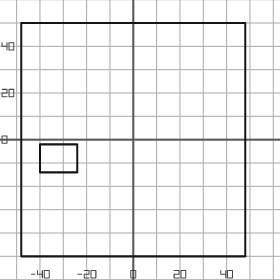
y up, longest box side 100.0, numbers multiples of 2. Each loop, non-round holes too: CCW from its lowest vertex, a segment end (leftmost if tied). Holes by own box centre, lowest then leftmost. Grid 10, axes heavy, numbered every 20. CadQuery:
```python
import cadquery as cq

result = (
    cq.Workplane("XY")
    .moveTo(-48.0, -50.0)
    .lineTo(48.0, -50.0)
    .lineTo(48.0, 50.0)
    .lineTo(-48.0, 50.0)
    .close()
    .moveTo(-40.0, -14.0)
    .lineTo(-24.0, -14.0)
    .lineTo(-24.0, -2.0)
    .lineTo(-40.0, -2.0)
    .close()
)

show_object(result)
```